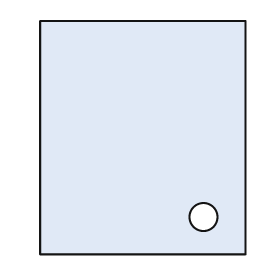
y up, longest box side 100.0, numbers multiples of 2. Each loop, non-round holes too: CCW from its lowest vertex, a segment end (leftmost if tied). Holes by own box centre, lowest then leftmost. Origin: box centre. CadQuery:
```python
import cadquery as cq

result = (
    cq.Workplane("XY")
    .moveTo(-44.0, -50.0)
    .lineTo(44.0, -50.0)
    .lineTo(44.0, 50.0)
    .lineTo(-44.0, 50.0)
    .close()
    .moveTo(26.0, -34.0)
    .circle(6.0)
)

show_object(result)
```